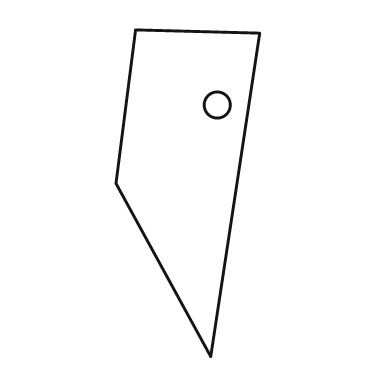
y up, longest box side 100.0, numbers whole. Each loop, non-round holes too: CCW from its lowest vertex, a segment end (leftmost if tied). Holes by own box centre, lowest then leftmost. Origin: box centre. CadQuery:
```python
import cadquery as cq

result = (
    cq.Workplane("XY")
    .moveTo(7.0, -50.0)
    .lineTo(22.0, 49.0)
    .lineTo(-16.0, 50.0)
    .lineTo(-22.0, 3.0)
    .close()
    .moveTo(9.0, 27.0)
    .circle(4.0)
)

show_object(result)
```